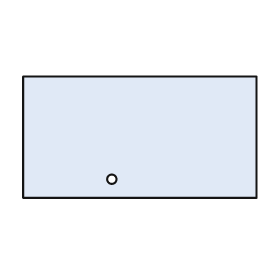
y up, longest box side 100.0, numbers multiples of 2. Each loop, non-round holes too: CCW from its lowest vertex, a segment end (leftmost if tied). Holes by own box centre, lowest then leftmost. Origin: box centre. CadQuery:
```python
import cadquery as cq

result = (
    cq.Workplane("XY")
    .moveTo(-50.0, -26.0)
    .lineTo(50.0, -26.0)
    .lineTo(50.0, 26.0)
    .lineTo(-50.0, 26.0)
    .close()
    .moveTo(-12.0, -18.0)
    .circle(2.0)
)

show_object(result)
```